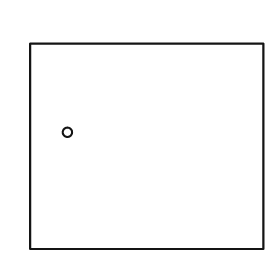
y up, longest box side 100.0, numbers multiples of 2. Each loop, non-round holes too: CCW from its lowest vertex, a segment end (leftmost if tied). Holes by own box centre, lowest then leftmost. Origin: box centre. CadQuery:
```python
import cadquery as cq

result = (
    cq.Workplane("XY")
    .moveTo(-50.0, -44.0)
    .lineTo(50.0, -44.0)
    .lineTo(50.0, 44.0)
    .lineTo(-50.0, 44.0)
    .close()
    .moveTo(-34.0, 6.0)
    .circle(2.0)
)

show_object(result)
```